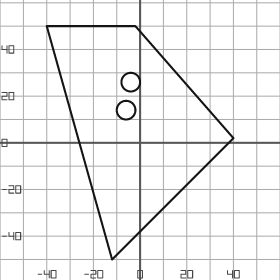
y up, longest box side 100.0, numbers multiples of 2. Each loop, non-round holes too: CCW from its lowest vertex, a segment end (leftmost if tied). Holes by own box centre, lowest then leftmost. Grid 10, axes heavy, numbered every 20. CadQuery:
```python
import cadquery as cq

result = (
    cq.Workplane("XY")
    .moveTo(-12.0, -50.0)
    .lineTo(40.0, 2.0)
    .lineTo(-2.0, 50.0)
    .lineTo(-40.0, 50.0)
    .close()
    .moveTo(-6.0, 14.0)
    .circle(4.0)
    .moveTo(-4.0, 26.0)
    .circle(4.0)
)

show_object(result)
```